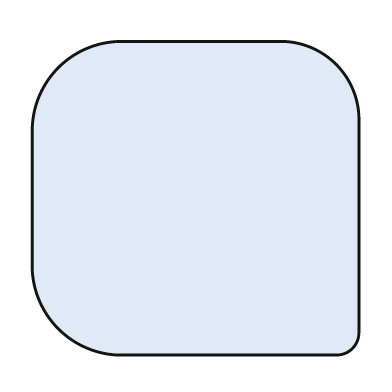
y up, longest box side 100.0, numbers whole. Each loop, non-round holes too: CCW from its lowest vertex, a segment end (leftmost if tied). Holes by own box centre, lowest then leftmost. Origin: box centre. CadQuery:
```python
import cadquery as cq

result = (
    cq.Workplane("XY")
    .moveTo(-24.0, -48.0)
    .lineTo(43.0, -48.0)
    .threePointArc((48.0, -46.0), (50.0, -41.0))
    .lineTo(50.0, 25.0)
    .threePointArc((43.0, 41.0), (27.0, 48.0))
    .lineTo(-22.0, 48.0)
    .threePointArc((-42.0, 40.0), (-50.0, 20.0))
    .lineTo(-50.0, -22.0)
    .threePointArc((-42.0, -40.0), (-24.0, -48.0))
    .close()
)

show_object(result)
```